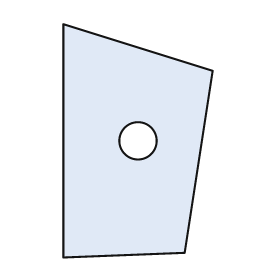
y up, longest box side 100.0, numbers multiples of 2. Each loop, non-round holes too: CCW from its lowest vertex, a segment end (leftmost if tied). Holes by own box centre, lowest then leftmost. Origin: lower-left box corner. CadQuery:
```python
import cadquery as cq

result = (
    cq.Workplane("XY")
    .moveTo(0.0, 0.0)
    .lineTo(52.0, 2.0)
    .lineTo(64.0, 80.0)
    .lineTo(0.0, 100.0)
    .close()
    .moveTo(32.0, 50.0)
    .circle(8.0)
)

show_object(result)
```